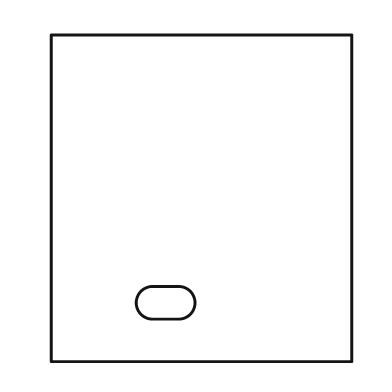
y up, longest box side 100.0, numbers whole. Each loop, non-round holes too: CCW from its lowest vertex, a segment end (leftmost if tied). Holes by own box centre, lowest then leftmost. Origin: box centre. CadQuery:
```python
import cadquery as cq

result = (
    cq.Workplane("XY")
    .moveTo(-46.0, -50.0)
    .lineTo(46.0, -50.0)
    .lineTo(46.0, 50.0)
    .lineTo(-46.0, 50.0)
    .close()
    .moveTo(-15.0, -37.0)
    .lineTo(-7.0, -37.0)
    .threePointArc((-2.0, -32.0), (-7.0, -27.0))
    .lineTo(-15.0, -27.0)
    .threePointArc((-20.0, -32.0), (-15.0, -37.0))
    .close()
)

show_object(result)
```